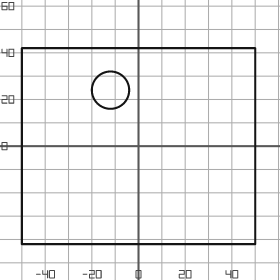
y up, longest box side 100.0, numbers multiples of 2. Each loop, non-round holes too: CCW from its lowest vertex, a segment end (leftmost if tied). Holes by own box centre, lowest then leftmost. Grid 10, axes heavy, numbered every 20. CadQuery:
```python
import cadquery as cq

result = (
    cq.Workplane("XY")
    .moveTo(-50.0, -42.0)
    .lineTo(50.0, -42.0)
    .lineTo(50.0, 42.0)
    .lineTo(-50.0, 42.0)
    .close()
    .moveTo(-12.0, 24.0)
    .circle(8.0)
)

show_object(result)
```